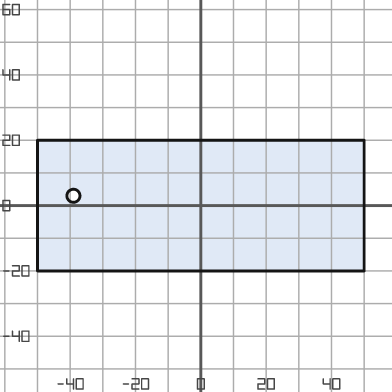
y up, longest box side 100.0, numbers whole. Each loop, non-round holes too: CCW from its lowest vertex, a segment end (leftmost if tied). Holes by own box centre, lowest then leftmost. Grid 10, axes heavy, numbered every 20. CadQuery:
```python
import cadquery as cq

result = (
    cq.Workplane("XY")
    .moveTo(-50.0, -20.0)
    .lineTo(50.0, -20.0)
    .lineTo(50.0, 20.0)
    .lineTo(-50.0, 20.0)
    .close()
    .moveTo(-39.0, 3.0)
    .circle(2.0)
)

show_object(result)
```